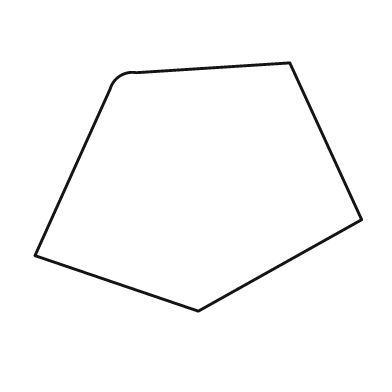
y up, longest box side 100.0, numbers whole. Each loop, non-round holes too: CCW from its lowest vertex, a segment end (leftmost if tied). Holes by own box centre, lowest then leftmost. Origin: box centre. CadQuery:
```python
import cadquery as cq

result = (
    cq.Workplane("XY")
    .moveTo(0.0, -38.0)
    .lineTo(50.0, -10.0)
    .lineTo(28.0, 38.0)
    .lineTo(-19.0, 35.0)
    .threePointArc((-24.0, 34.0), (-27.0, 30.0))
    .lineTo(-50.0, -21.0)
    .close()
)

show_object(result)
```